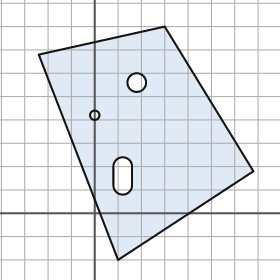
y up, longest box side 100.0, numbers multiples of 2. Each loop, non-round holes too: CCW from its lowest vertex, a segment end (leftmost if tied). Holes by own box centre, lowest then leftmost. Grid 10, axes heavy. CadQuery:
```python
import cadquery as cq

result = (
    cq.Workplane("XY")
    .moveTo(10.0, -20.0)
    .lineTo(68.0, 18.0)
    .lineTo(30.0, 80.0)
    .lineTo(-24.0, 68.0)
    .close()
    .moveTo(8.0, 12.0)
    .threePointArc((12.0, 8.0), (16.0, 12.0))
    .lineTo(16.0, 20.0)
    .threePointArc((12.0, 24.0), (8.0, 20.0))
    .close()
    .moveTo(0.0, 42.0)
    .circle(2.0)
    .moveTo(18.0, 56.0)
    .circle(4.0)
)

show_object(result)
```